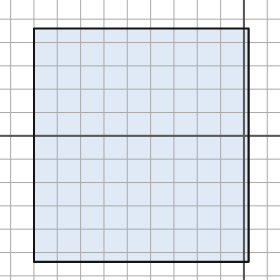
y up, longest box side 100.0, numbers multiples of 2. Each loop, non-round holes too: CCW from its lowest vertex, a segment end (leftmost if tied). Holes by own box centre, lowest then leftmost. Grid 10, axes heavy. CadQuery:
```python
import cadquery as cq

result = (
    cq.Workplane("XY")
    .moveTo(-90.0, -54.0)
    .lineTo(2.0, -54.0)
    .lineTo(2.0, 46.0)
    .lineTo(-90.0, 46.0)
    .close()
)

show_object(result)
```